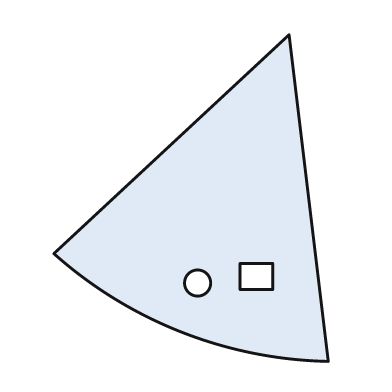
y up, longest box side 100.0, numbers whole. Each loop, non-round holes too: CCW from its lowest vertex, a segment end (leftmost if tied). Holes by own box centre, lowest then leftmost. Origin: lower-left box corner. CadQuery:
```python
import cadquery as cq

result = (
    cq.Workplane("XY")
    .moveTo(84.0, 0.0)
    .lineTo(72.0, 100.0)
    .lineTo(0.0, 33.0)
    .threePointArc((39.0, 9.0), (84.0, 0.0))
    .close()
    .moveTo(44.0, 24.0)
    .circle(4.0)
    .moveTo(57.0, 22.0)
    .lineTo(67.0, 22.0)
    .lineTo(67.0, 30.0)
    .lineTo(57.0, 30.0)
    .close()
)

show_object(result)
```